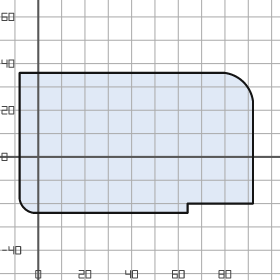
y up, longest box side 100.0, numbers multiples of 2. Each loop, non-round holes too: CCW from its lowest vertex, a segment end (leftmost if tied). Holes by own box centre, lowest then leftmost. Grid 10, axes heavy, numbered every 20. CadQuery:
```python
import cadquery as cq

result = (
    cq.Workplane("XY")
    .moveTo(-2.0, -24.0)
    .lineTo(64.0, -24.0)
    .lineTo(64.0, -20.0)
    .lineTo(92.0, -20.0)
    .lineTo(92.0, 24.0)
    .threePointArc((88.0, 32.0), (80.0, 36.0))
    .lineTo(-8.0, 36.0)
    .lineTo(-8.0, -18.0)
    .threePointArc((-6.0, -22.0), (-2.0, -24.0))
    .close()
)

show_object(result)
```